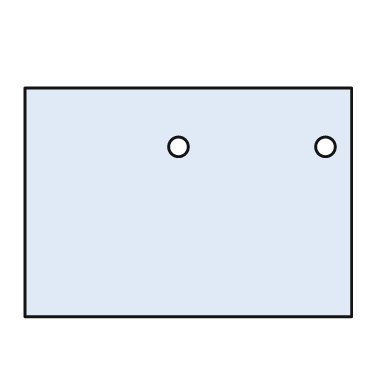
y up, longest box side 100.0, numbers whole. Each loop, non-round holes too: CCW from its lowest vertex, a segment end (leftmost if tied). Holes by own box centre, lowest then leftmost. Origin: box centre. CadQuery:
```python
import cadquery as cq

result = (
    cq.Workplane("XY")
    .moveTo(-50.0, -35.0)
    .lineTo(50.0, -35.0)
    .lineTo(50.0, 35.0)
    .lineTo(-50.0, 35.0)
    .close()
    .moveTo(-3.0, 17.0)
    .circle(3.0)
    .moveTo(42.0, 17.0)
    .circle(3.0)
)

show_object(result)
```